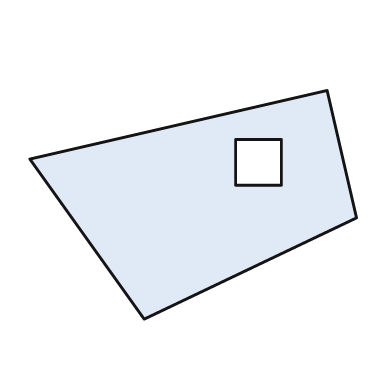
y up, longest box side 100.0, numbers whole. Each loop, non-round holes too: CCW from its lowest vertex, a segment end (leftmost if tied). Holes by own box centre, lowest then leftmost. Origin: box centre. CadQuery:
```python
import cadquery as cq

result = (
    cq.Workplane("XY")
    .moveTo(-15.0, -35.0)
    .lineTo(50.0, -4.0)
    .lineTo(41.0, 35.0)
    .lineTo(-50.0, 14.0)
    .close()
    .moveTo(13.0, 6.0)
    .lineTo(27.0, 6.0)
    .lineTo(27.0, 20.0)
    .lineTo(13.0, 20.0)
    .close()
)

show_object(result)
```